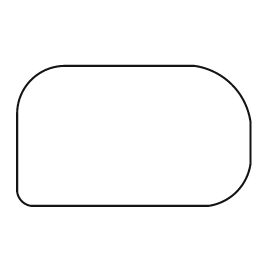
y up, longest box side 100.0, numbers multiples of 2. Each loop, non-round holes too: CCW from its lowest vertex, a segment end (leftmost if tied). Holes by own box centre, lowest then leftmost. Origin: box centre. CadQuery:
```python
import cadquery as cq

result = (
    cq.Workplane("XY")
    .moveTo(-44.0, -30.0)
    .lineTo(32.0, -30.0)
    .threePointArc((44.0, -24.0), (50.0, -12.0))
    .lineTo(50.0, 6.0)
    .threePointArc((42.0, 22.0), (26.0, 30.0))
    .lineTo(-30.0, 30.0)
    .threePointArc((-44.0, 24.0), (-50.0, 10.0))
    .lineTo(-50.0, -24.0)
    .threePointArc((-48.0, -28.0), (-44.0, -30.0))
    .close()
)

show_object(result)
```